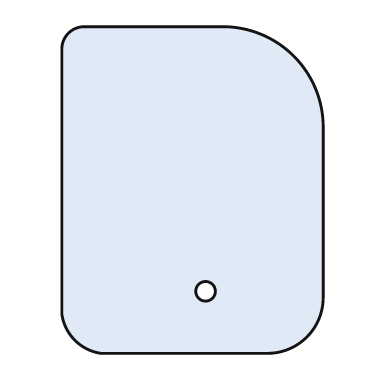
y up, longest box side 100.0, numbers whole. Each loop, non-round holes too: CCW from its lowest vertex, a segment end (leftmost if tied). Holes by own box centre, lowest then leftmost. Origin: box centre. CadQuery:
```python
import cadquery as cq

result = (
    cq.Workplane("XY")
    .moveTo(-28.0, -50.0)
    .lineTo(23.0, -50.0)
    .threePointArc((35.0, -45.0), (40.0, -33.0))
    .lineTo(40.0, 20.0)
    .threePointArc((31.0, 41.0), (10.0, 50.0))
    .lineTo(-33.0, 50.0)
    .threePointArc((-38.0, 48.0), (-40.0, 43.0))
    .lineTo(-40.0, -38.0)
    .threePointArc((-36.0, -46.0), (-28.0, -50.0))
    .close()
    .moveTo(4.0, -31.0)
    .circle(3.0)
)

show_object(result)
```